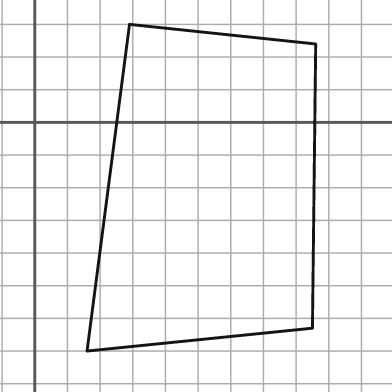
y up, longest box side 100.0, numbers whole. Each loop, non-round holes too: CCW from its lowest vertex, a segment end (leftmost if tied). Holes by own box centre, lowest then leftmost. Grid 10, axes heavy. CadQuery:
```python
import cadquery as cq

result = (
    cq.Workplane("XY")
    .moveTo(16.0, -70.0)
    .lineTo(85.0, -63.0)
    .lineTo(86.0, 24.0)
    .lineTo(29.0, 30.0)
    .close()
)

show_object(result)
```